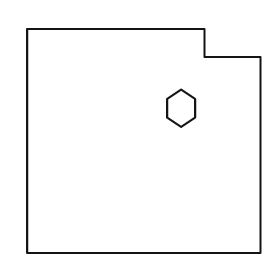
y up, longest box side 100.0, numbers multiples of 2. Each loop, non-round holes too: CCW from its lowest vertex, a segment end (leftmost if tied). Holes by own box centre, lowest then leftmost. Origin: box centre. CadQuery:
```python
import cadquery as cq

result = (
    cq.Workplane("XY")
    .moveTo(-50.0, -48.0)
    .lineTo(50.0, -48.0)
    .lineTo(50.0, 36.0)
    .lineTo(26.0, 36.0)
    .lineTo(26.0, 48.0)
    .lineTo(-50.0, 48.0)
    .close()
    .moveTo(16.0, 6.0)
    .lineTo(22.0, 10.0)
    .lineTo(22.0, 18.0)
    .lineTo(16.0, 22.0)
    .lineTo(10.0, 18.0)
    .lineTo(10.0, 10.0)
    .close()
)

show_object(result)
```